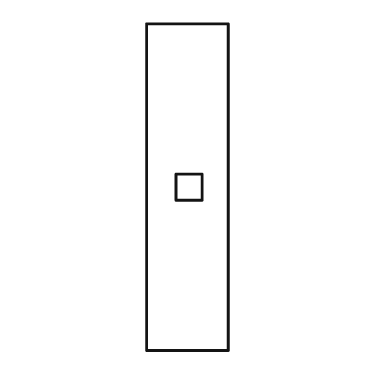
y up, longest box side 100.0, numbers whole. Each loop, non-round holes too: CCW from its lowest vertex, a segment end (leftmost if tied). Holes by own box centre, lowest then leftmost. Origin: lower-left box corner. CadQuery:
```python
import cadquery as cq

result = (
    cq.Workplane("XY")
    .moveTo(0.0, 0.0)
    .lineTo(25.0, 0.0)
    .lineTo(25.0, 100.0)
    .lineTo(0.0, 100.0)
    .close()
    .moveTo(9.0, 46.0)
    .lineTo(17.0, 46.0)
    .lineTo(17.0, 54.0)
    .lineTo(9.0, 54.0)
    .close()
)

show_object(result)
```